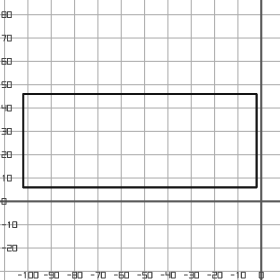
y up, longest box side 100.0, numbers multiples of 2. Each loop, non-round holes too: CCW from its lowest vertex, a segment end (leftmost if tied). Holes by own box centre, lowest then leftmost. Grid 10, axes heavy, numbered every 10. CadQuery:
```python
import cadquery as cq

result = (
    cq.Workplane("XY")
    .moveTo(-102.0, 6.0)
    .lineTo(-2.0, 6.0)
    .lineTo(-2.0, 46.0)
    .lineTo(-102.0, 46.0)
    .close()
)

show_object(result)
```